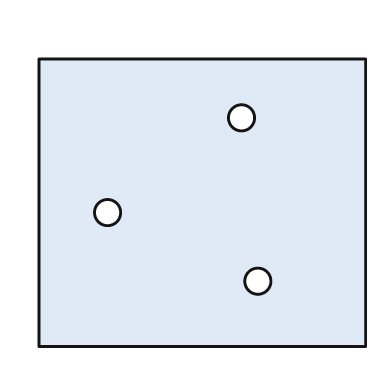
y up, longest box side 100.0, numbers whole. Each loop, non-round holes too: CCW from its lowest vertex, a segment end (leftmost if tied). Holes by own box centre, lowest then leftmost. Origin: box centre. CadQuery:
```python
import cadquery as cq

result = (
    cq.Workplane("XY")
    .moveTo(-50.0, -44.0)
    .lineTo(50.0, -44.0)
    .lineTo(50.0, 44.0)
    .lineTo(-50.0, 44.0)
    .close()
    .moveTo(17.0, -24.0)
    .circle(4.0)
    .moveTo(-29.0, -3.0)
    .circle(4.0)
    .moveTo(12.0, 26.0)
    .circle(4.0)
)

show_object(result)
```